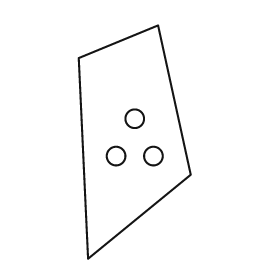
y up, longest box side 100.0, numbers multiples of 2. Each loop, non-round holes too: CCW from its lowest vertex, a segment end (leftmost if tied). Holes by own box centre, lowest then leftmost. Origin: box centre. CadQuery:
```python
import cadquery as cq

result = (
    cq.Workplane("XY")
    .moveTo(-20.0, -50.0)
    .lineTo(24.0, -14.0)
    .lineTo(10.0, 50.0)
    .lineTo(-24.0, 36.0)
    .close()
    .moveTo(-8.0, -6.0)
    .circle(4.0)
    .moveTo(8.0, -6.0)
    .circle(4.0)
    .moveTo(0.0, 10.0)
    .circle(4.0)
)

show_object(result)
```